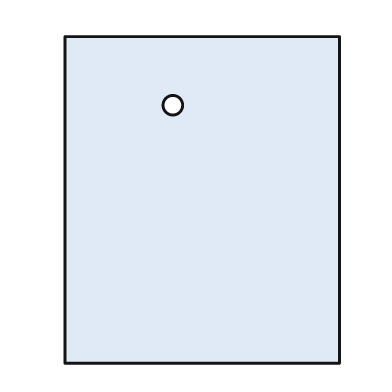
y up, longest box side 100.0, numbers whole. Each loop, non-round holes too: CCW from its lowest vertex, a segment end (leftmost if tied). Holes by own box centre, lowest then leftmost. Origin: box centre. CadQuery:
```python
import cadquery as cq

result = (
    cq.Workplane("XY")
    .moveTo(-42.0, -50.0)
    .lineTo(42.0, -50.0)
    .lineTo(42.0, 50.0)
    .lineTo(-42.0, 50.0)
    .close()
    .moveTo(-9.0, 29.0)
    .circle(3.0)
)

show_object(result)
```